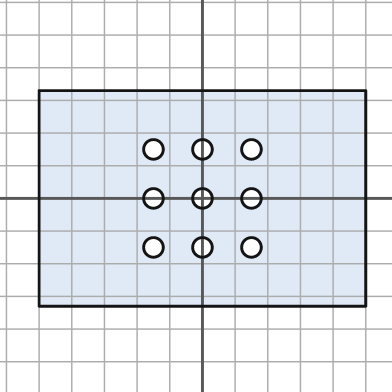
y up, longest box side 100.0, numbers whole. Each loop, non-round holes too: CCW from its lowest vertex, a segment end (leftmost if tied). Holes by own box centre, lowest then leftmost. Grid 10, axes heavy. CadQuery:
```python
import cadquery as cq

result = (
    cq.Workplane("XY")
    .moveTo(-50.0, -33.0)
    .lineTo(50.0, -33.0)
    .lineTo(50.0, 33.0)
    .lineTo(-50.0, 33.0)
    .close()
    .moveTo(-15.0, -15.0)
    .circle(3.0)
    .moveTo(0.0, -15.0)
    .circle(3.0)
    .moveTo(15.0, -15.0)
    .circle(3.0)
    .moveTo(-15.0, 0.0)
    .circle(3.0)
    .moveTo(0.0, 0.0)
    .circle(3.0)
    .moveTo(15.0, 0.0)
    .circle(3.0)
    .moveTo(-15.0, 15.0)
    .circle(3.0)
    .moveTo(0.0, 15.0)
    .circle(3.0)
    .moveTo(15.0, 15.0)
    .circle(3.0)
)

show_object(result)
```